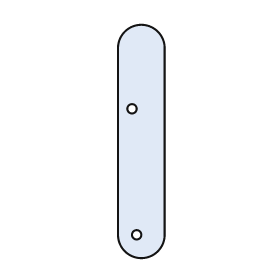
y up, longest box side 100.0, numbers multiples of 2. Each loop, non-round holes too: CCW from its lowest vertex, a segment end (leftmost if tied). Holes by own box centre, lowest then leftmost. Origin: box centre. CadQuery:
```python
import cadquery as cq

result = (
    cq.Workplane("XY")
    .moveTo(-10.0, -40.0)
    .threePointArc((0.0, -50.0), (10.0, -40.0))
    .lineTo(10.0, 40.0)
    .threePointArc((0.0, 50.0), (-10.0, 40.0))
    .close()
    .moveTo(-2.0, -40.0)
    .circle(2.0)
    .moveTo(-4.0, 14.0)
    .circle(2.0)
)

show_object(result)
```